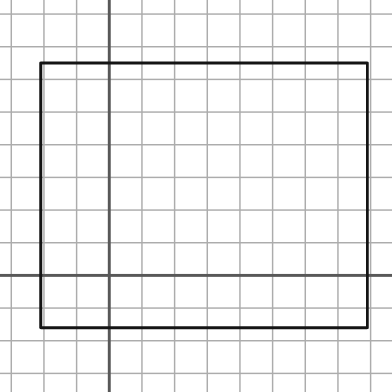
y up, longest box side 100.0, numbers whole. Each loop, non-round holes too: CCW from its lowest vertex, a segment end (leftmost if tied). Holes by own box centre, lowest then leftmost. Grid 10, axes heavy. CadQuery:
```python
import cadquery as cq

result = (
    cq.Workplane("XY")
    .moveTo(-21.0, -16.0)
    .lineTo(79.0, -16.0)
    .lineTo(79.0, 65.0)
    .lineTo(-21.0, 65.0)
    .close()
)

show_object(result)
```